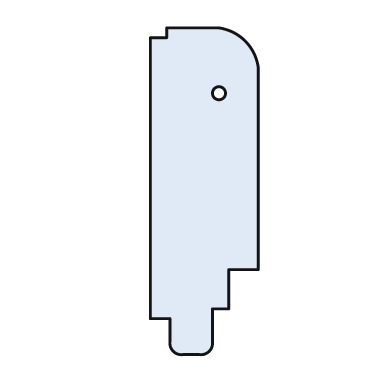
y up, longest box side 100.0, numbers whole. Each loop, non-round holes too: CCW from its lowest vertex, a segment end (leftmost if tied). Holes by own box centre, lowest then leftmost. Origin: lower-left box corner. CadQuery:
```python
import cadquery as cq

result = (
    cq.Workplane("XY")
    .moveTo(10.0, 0.0)
    .lineTo(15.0, 0.0)
    .threePointArc((18.0, 1.0), (19.0, 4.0))
    .lineTo(19.0, 14.0)
    .lineTo(24.0, 14.0)
    .lineTo(24.0, 26.0)
    .lineTo(33.0, 26.0)
    .lineTo(33.0, 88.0)
    .threePointArc((29.0, 96.0), (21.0, 100.0))
    .lineTo(5.0, 100.0)
    .lineTo(5.0, 97.0)
    .lineTo(0.0, 97.0)
    .lineTo(0.0, 11.0)
    .lineTo(6.0, 11.0)
    .lineTo(6.0, 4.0)
    .threePointArc((7.0, 1.0), (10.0, 0.0))
    .close()
    .moveTo(21.0, 80.0)
    .circle(2.0)
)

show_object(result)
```